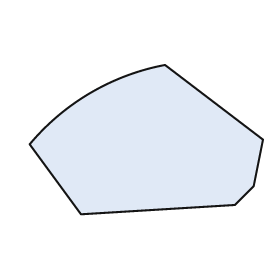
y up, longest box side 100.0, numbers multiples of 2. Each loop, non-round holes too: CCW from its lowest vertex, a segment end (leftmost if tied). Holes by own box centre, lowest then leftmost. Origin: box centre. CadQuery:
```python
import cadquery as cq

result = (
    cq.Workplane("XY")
    .moveTo(-28.0, -32.0)
    .lineTo(38.0, -28.0)
    .lineTo(46.0, -20.0)
    .lineTo(50.0, 0.0)
    .lineTo(8.0, 32.0)
    .threePointArc((-24.0, 20.0), (-50.0, -2.0))
    .close()
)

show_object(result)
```